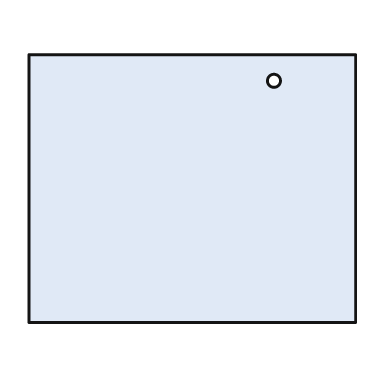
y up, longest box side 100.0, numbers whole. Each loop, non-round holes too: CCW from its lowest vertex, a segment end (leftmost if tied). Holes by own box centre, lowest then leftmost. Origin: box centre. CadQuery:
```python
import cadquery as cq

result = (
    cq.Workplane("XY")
    .moveTo(-50.0, -41.0)
    .lineTo(50.0, -41.0)
    .lineTo(50.0, 41.0)
    .lineTo(-50.0, 41.0)
    .close()
    .moveTo(25.0, 33.0)
    .circle(2.0)
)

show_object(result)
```